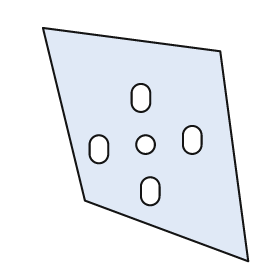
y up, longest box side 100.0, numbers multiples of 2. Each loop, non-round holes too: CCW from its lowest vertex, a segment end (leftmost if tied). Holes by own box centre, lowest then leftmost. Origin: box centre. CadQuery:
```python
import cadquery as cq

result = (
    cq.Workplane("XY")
    .moveTo(44.0, -50.0)
    .lineTo(32.0, 40.0)
    .lineTo(-44.0, 50.0)
    .lineTo(-26.0, -24.0)
    .close()
    .moveTo(-2.0, -22.0)
    .threePointArc((2.0, -26.0), (6.0, -22.0))
    .lineTo(6.0, -18.0)
    .threePointArc((2.0, -14.0), (-2.0, -18.0))
    .close()
    .moveTo(-24.0, -4.0)
    .threePointArc((-20.0, -8.0), (-16.0, -4.0))
    .lineTo(-16.0, 0.0)
    .threePointArc((-20.0, 4.0), (-24.0, 0.0))
    .close()
    .moveTo(0.0, 0.0)
    .circle(4.0)
    .moveTo(16.0, 0.0)
    .threePointArc((20.0, -4.0), (24.0, 0.0))
    .lineTo(24.0, 4.0)
    .threePointArc((20.0, 8.0), (16.0, 4.0))
    .close()
    .moveTo(-6.0, 18.0)
    .threePointArc((-2.0, 14.0), (2.0, 18.0))
    .lineTo(2.0, 22.0)
    .threePointArc((-2.0, 26.0), (-6.0, 22.0))
    .close()
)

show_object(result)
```